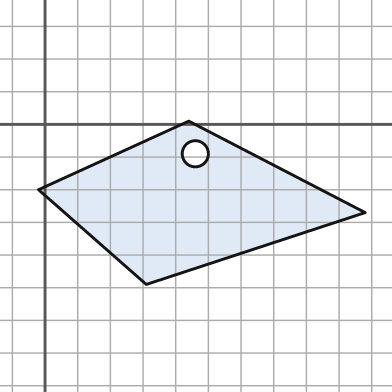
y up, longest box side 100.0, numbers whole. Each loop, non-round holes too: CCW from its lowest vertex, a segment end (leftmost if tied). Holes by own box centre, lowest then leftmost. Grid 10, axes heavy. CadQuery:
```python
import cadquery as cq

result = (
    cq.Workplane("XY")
    .moveTo(31.0, -49.0)
    .lineTo(98.0, -27.0)
    .lineTo(44.0, 1.0)
    .lineTo(-2.0, -20.0)
    .close()
    .moveTo(46.0, -9.0)
    .circle(4.0)
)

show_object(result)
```